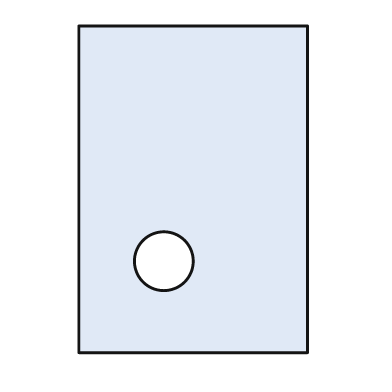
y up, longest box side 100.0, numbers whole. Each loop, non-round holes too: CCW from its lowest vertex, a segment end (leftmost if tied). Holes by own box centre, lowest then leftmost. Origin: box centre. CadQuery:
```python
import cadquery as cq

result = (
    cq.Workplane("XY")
    .moveTo(-35.0, -50.0)
    .lineTo(35.0, -50.0)
    .lineTo(35.0, 50.0)
    .lineTo(-35.0, 50.0)
    .close()
    .moveTo(-9.0, -22.0)
    .circle(9.0)
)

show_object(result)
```